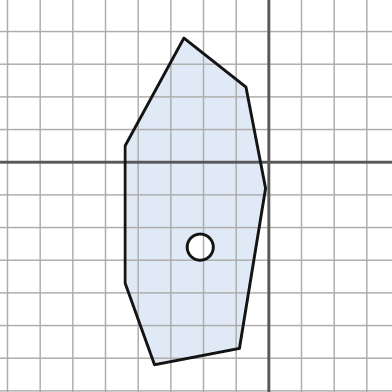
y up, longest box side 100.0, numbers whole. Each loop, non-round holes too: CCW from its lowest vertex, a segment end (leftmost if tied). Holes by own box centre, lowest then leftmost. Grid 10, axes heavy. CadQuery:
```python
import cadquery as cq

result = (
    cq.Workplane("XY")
    .moveTo(-35.0, -62.0)
    .lineTo(-9.0, -57.0)
    .lineTo(-1.0, -8.0)
    .lineTo(-7.0, 23.0)
    .lineTo(-26.0, 38.0)
    .lineTo(-44.0, 5.0)
    .lineTo(-44.0, -37.0)
    .close()
    .moveTo(-21.0, -26.0)
    .circle(4.0)
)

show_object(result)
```